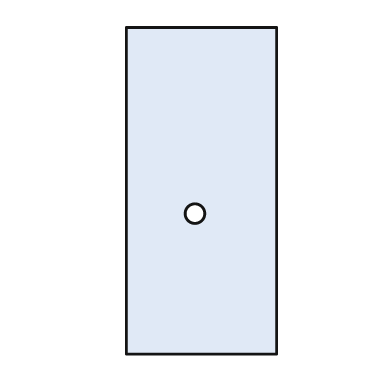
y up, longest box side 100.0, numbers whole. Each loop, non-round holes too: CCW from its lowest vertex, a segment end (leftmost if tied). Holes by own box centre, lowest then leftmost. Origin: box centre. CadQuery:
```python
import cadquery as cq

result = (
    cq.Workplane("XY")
    .moveTo(-23.0, -50.0)
    .lineTo(23.0, -50.0)
    .lineTo(23.0, 50.0)
    .lineTo(-23.0, 50.0)
    .close()
    .moveTo(-2.0, -7.0)
    .circle(3.0)
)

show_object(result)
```